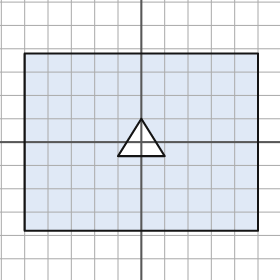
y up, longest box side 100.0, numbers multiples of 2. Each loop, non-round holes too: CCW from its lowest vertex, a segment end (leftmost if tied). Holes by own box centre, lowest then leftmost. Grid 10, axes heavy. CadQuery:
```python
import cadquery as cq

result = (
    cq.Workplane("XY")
    .moveTo(-50.0, -38.0)
    .lineTo(50.0, -38.0)
    .lineTo(50.0, 38.0)
    .lineTo(-50.0, 38.0)
    .close()
    .moveTo(-10.0, -6.0)
    .lineTo(10.0, -6.0)
    .lineTo(0.0, 10.0)
    .close()
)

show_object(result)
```